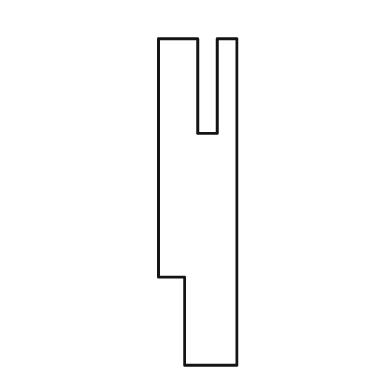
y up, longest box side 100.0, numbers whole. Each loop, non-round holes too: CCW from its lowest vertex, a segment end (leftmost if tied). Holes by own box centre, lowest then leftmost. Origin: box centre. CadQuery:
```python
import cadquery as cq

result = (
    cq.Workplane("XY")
    .moveTo(-4.0, -50.0)
    .lineTo(12.0, -50.0)
    .lineTo(12.0, 50.0)
    .lineTo(6.0, 50.0)
    .lineTo(6.0, 21.0)
    .lineTo(0.0, 21.0)
    .lineTo(0.0, 50.0)
    .lineTo(-12.0, 50.0)
    .lineTo(-12.0, -23.0)
    .lineTo(-4.0, -23.0)
    .close()
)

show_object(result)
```